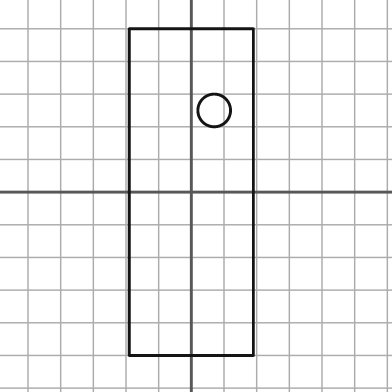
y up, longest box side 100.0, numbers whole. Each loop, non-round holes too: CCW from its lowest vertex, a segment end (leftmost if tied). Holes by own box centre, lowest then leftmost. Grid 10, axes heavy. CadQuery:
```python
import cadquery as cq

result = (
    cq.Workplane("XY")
    .moveTo(-19.0, -50.0)
    .lineTo(19.0, -50.0)
    .lineTo(19.0, 50.0)
    .lineTo(-19.0, 50.0)
    .close()
    .moveTo(7.0, 25.0)
    .circle(5.0)
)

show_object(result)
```